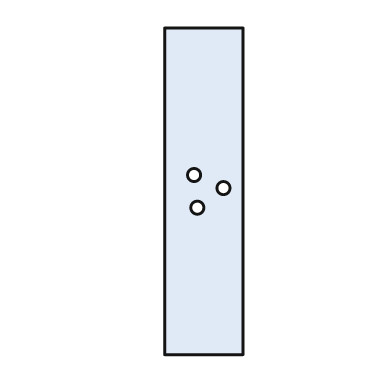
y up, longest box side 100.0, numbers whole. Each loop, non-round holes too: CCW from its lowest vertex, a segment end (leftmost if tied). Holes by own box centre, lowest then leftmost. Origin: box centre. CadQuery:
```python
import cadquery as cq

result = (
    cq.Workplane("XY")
    .moveTo(-12.0, -50.0)
    .lineTo(12.0, -50.0)
    .lineTo(12.0, 50.0)
    .lineTo(-12.0, 50.0)
    .close()
    .moveTo(-2.0, -5.0)
    .circle(2.0)
    .moveTo(6.0, 1.0)
    .circle(2.0)
    .moveTo(-3.0, 5.0)
    .circle(2.0)
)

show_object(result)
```